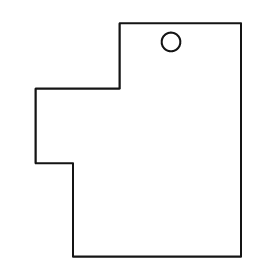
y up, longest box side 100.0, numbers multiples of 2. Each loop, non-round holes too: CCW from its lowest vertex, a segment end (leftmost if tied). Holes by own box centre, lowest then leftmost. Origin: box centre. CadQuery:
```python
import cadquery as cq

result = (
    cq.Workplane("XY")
    .moveTo(-28.0, -50.0)
    .lineTo(44.0, -50.0)
    .lineTo(44.0, 50.0)
    .lineTo(-8.0, 50.0)
    .lineTo(-8.0, 22.0)
    .lineTo(-44.0, 22.0)
    .lineTo(-44.0, -10.0)
    .lineTo(-28.0, -10.0)
    .close()
    .moveTo(14.0, 42.0)
    .circle(4.0)
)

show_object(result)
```